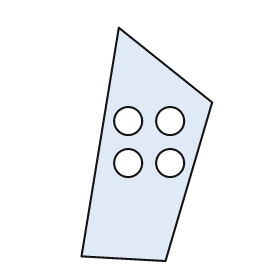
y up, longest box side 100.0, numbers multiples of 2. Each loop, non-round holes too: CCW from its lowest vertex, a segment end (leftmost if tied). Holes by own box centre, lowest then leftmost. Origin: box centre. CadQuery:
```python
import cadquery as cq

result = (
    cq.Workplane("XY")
    .moveTo(8.0, -50.0)
    .lineTo(28.0, 18.0)
    .lineTo(-12.0, 50.0)
    .lineTo(-28.0, -48.0)
    .close()
    .moveTo(-8.0, -8.0)
    .circle(6.0)
    .moveTo(10.0, -8.0)
    .circle(6.0)
    .moveTo(-8.0, 10.0)
    .circle(6.0)
    .moveTo(10.0, 10.0)
    .circle(6.0)
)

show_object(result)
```